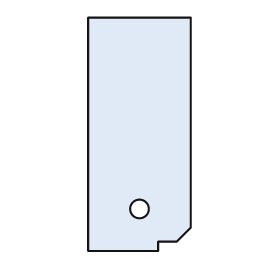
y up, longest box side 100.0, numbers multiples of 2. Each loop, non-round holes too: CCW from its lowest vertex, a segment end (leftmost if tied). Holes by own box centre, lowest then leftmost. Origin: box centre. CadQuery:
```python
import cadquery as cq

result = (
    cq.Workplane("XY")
    .moveTo(-22.0, -50.0)
    .lineTo(8.0, -50.0)
    .lineTo(8.0, -46.0)
    .lineTo(16.0, -46.0)
    .lineTo(22.0, -40.0)
    .lineTo(22.0, 50.0)
    .lineTo(-22.0, 50.0)
    .close()
    .moveTo(0.0, -32.0)
    .circle(4.0)
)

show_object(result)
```